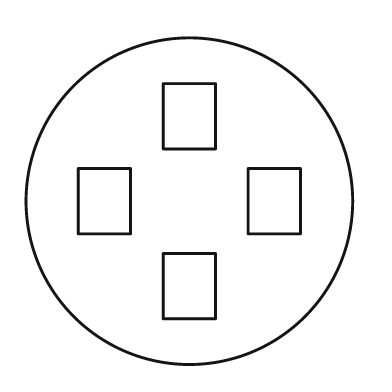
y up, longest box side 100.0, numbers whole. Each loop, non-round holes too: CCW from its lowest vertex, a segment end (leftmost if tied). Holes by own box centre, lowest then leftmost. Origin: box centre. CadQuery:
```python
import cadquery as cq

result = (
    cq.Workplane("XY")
    .moveTo(0.0, 0.0)
    .circle(50.0)
    .moveTo(-8.0, -36.0)
    .lineTo(8.0, -36.0)
    .lineTo(8.0, -16.0)
    .lineTo(-8.0, -16.0)
    .close()
    .moveTo(-34.0, -10.0)
    .lineTo(-18.0, -10.0)
    .lineTo(-18.0, 10.0)
    .lineTo(-34.0, 10.0)
    .close()
    .moveTo(18.0, -10.0)
    .lineTo(34.0, -10.0)
    .lineTo(34.0, 10.0)
    .lineTo(18.0, 10.0)
    .close()
    .moveTo(-8.0, 16.0)
    .lineTo(8.0, 16.0)
    .lineTo(8.0, 36.0)
    .lineTo(-8.0, 36.0)
    .close()
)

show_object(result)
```